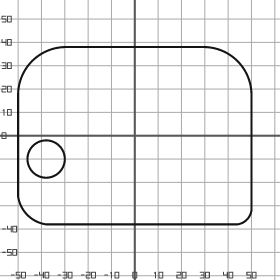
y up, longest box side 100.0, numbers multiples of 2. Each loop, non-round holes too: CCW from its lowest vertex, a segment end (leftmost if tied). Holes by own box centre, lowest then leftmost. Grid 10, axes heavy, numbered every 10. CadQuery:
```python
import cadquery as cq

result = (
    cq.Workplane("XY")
    .moveTo(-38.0, -38.0)
    .lineTo(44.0, -38.0)
    .threePointArc((48.0, -36.0), (50.0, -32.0))
    .lineTo(50.0, 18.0)
    .threePointArc((44.0, 32.0), (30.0, 38.0))
    .lineTo(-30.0, 38.0)
    .threePointArc((-44.0, 32.0), (-50.0, 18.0))
    .lineTo(-50.0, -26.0)
    .threePointArc((-46.0, -34.0), (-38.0, -38.0))
    .close()
    .moveTo(-38.0, -10.0)
    .circle(8.0)
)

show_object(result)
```